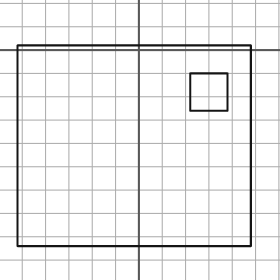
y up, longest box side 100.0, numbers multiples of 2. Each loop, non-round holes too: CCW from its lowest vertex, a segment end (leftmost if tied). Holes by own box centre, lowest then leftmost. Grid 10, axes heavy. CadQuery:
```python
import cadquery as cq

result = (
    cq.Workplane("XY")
    .moveTo(-52.0, -84.0)
    .lineTo(48.0, -84.0)
    .lineTo(48.0, 2.0)
    .lineTo(-52.0, 2.0)
    .close()
    .moveTo(22.0, -26.0)
    .lineTo(38.0, -26.0)
    .lineTo(38.0, -10.0)
    .lineTo(22.0, -10.0)
    .close()
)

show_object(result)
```